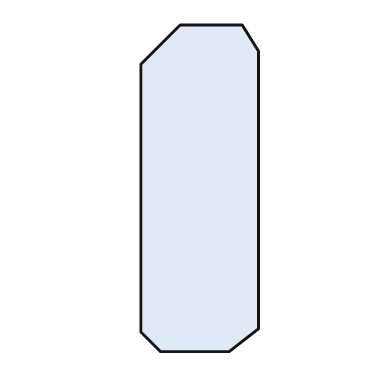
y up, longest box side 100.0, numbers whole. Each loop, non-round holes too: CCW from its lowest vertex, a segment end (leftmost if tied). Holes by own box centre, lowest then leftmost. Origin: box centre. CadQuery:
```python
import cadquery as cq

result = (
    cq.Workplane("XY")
    .moveTo(-12.0, -50.0)
    .lineTo(9.0, -50.0)
    .lineTo(18.0, -43.0)
    .lineTo(18.0, 42.0)
    .lineTo(13.0, 50.0)
    .lineTo(-6.0, 50.0)
    .lineTo(-18.0, 38.0)
    .lineTo(-18.0, -44.0)
    .close()
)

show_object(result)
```